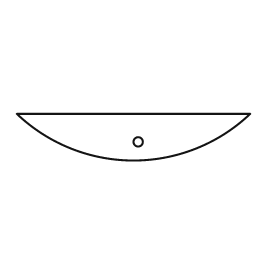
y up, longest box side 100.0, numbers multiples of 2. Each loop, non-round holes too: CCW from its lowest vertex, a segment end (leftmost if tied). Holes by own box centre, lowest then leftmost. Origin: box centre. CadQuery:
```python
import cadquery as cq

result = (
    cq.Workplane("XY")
    .moveTo(-50.0, 10.0)
    .threePointArc((0.0, -10.0), (50.0, 10.0))
    .close()
    .moveTo(2.0, -2.0)
    .circle(2.0)
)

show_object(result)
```